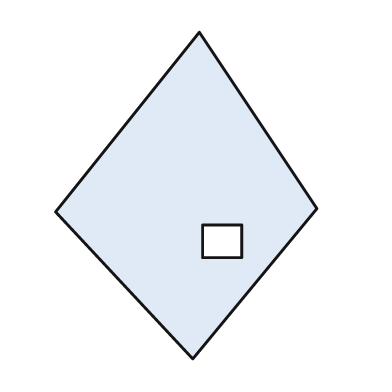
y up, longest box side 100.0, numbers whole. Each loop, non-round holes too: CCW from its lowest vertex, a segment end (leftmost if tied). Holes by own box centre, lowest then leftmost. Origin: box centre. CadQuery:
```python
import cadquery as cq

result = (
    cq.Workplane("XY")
    .moveTo(2.0, -50.0)
    .lineTo(40.0, -4.0)
    .lineTo(4.0, 50.0)
    .lineTo(-40.0, -5.0)
    .close()
    .moveTo(5.0, -19.0)
    .lineTo(17.0, -19.0)
    .lineTo(17.0, -9.0)
    .lineTo(5.0, -9.0)
    .close()
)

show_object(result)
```